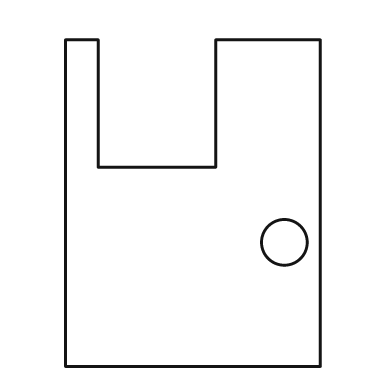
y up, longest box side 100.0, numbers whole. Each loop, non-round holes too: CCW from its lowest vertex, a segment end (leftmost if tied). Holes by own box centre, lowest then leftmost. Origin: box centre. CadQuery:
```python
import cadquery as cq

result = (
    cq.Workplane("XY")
    .moveTo(-39.0, -50.0)
    .lineTo(39.0, -50.0)
    .lineTo(39.0, 50.0)
    .lineTo(7.0, 50.0)
    .lineTo(7.0, 11.0)
    .lineTo(-29.0, 11.0)
    .lineTo(-29.0, 50.0)
    .lineTo(-39.0, 50.0)
    .close()
    .moveTo(28.0, -12.0)
    .circle(7.0)
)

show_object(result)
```